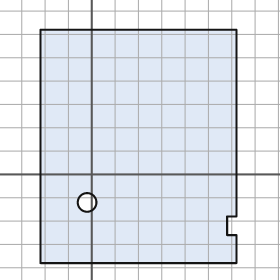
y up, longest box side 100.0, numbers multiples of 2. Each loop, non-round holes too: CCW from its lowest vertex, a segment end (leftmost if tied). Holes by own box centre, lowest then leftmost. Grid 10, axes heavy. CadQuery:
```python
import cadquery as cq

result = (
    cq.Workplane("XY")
    .moveTo(-22.0, -38.0)
    .lineTo(62.0, -38.0)
    .lineTo(62.0, -26.0)
    .lineTo(58.0, -26.0)
    .lineTo(58.0, -18.0)
    .lineTo(62.0, -18.0)
    .lineTo(62.0, 62.0)
    .lineTo(-22.0, 62.0)
    .close()
    .moveTo(-2.0, -12.0)
    .circle(4.0)
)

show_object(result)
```